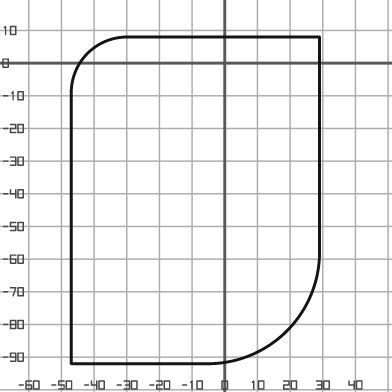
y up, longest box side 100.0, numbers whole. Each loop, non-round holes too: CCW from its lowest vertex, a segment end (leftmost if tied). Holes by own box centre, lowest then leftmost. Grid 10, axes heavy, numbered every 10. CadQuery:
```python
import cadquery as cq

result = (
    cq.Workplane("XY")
    .moveTo(-47.0, -92.0)
    .lineTo(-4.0, -92.0)
    .threePointArc((19.0, -82.0), (29.0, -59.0))
    .lineTo(29.0, 8.0)
    .lineTo(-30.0, 8.0)
    .threePointArc((-42.0, 3.0), (-47.0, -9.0))
    .close()
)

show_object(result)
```